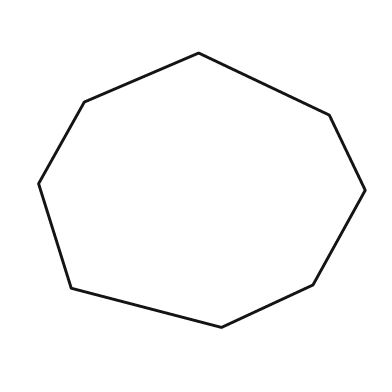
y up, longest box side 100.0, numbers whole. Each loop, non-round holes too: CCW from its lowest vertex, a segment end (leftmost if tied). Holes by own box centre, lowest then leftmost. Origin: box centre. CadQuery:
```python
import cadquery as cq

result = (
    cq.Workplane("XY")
    .moveTo(6.0, -42.0)
    .lineTo(34.0, -29.0)
    .lineTo(50.0, 0.0)
    .lineTo(39.0, 23.0)
    .lineTo(-1.0, 42.0)
    .lineTo(-36.0, 27.0)
    .lineTo(-50.0, 2.0)
    .lineTo(-40.0, -30.0)
    .close()
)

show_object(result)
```